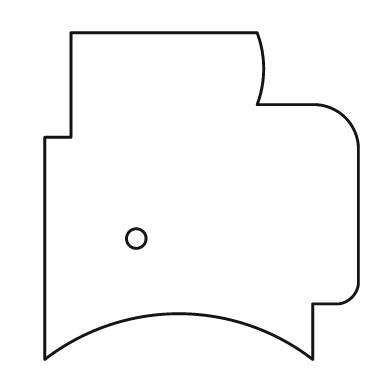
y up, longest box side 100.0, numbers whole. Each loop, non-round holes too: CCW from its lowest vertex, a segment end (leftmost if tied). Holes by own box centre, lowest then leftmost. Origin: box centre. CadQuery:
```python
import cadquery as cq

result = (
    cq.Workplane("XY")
    .moveTo(-48.0, -50.0)
    .threePointArc((-7.0, -36.0), (34.0, -50.0))
    .lineTo(34.0, -33.0)
    .lineTo(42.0, -33.0)
    .threePointArc((46.0, -31.0), (48.0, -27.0))
    .lineTo(48.0, 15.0)
    .threePointArc((44.0, 24.0), (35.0, 28.0))
    .lineTo(17.0, 28.0)
    .threePointArc((19.0, 39.0), (17.0, 50.0))
    .lineTo(-40.0, 50.0)
    .lineTo(-40.0, 18.0)
    .lineTo(-48.0, 18.0)
    .close()
    .moveTo(-20.0, -13.0)
    .circle(3.0)
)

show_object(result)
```